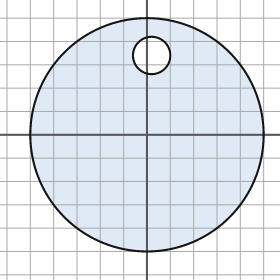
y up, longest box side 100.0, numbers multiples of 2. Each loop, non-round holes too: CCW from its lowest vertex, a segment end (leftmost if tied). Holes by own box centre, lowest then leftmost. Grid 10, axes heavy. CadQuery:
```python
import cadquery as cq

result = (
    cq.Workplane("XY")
    .moveTo(0.0, 0.0)
    .circle(50.0)
    .moveTo(2.0, 34.0)
    .circle(8.0)
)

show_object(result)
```